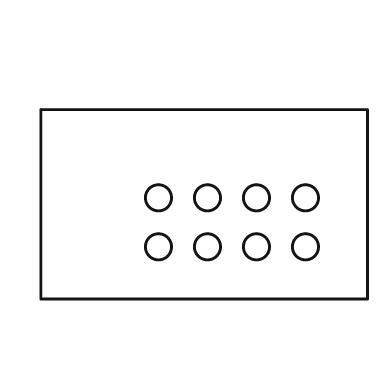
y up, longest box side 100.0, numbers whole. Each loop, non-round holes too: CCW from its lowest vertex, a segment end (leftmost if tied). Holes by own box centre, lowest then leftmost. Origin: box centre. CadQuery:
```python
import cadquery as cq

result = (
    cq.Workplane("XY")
    .moveTo(-50.0, -29.0)
    .lineTo(50.0, -29.0)
    .lineTo(50.0, 29.0)
    .lineTo(-50.0, 29.0)
    .close()
    .moveTo(-14.0, -13.0)
    .circle(4.0)
    .moveTo(1.0, -13.0)
    .circle(4.0)
    .moveTo(16.0, -13.0)
    .circle(4.0)
    .moveTo(31.0, -13.0)
    .circle(4.0)
    .moveTo(-14.0, 2.0)
    .circle(4.0)
    .moveTo(1.0, 2.0)
    .circle(4.0)
    .moveTo(16.0, 2.0)
    .circle(4.0)
    .moveTo(31.0, 2.0)
    .circle(4.0)
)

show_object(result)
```